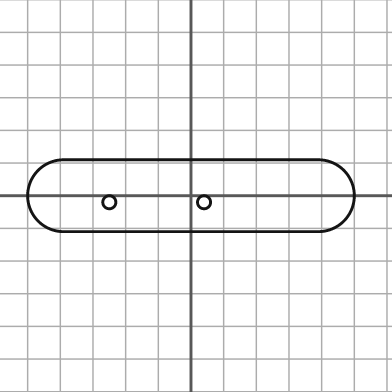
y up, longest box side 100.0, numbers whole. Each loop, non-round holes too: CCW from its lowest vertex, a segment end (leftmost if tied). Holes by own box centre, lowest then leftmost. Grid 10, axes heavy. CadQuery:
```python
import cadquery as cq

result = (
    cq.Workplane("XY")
    .moveTo(-39.0, -11.0)
    .lineTo(39.0, -11.0)
    .threePointArc((50.0, 0.0), (39.0, 11.0))
    .lineTo(-39.0, 11.0)
    .threePointArc((-50.0, 0.0), (-39.0, -11.0))
    .close()
    .moveTo(-25.0, -2.0)
    .circle(2.0)
    .moveTo(4.0, -2.0)
    .circle(2.0)
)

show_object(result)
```